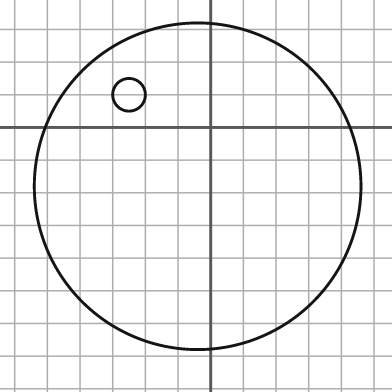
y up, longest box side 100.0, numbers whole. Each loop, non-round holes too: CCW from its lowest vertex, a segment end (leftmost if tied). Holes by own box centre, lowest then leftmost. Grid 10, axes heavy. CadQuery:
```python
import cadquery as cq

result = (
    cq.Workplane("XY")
    .moveTo(-4.0, -18.0)
    .circle(50.0)
    .moveTo(-25.0, 10.0)
    .circle(5.0)
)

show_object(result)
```